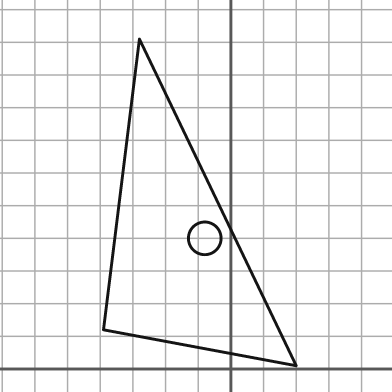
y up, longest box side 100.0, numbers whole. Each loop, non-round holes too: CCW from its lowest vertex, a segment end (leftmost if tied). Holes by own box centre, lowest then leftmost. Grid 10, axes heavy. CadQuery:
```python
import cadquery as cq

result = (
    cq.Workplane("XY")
    .moveTo(20.0, 1.0)
    .lineTo(-28.0, 101.0)
    .lineTo(-39.0, 12.0)
    .close()
    .moveTo(-8.0, 40.0)
    .circle(5.0)
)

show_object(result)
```